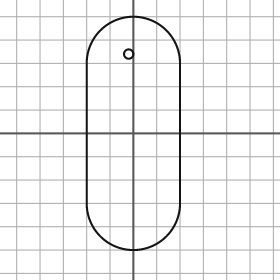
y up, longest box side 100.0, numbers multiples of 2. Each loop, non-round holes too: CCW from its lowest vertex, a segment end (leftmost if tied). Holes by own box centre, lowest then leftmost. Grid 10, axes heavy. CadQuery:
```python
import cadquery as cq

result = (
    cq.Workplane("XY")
    .moveTo(-20.0, -30.0)
    .threePointArc((0.0, -50.0), (20.0, -30.0))
    .lineTo(20.0, 30.0)
    .threePointArc((0.0, 50.0), (-20.0, 30.0))
    .close()
    .moveTo(-2.0, 34.0)
    .circle(2.0)
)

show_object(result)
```